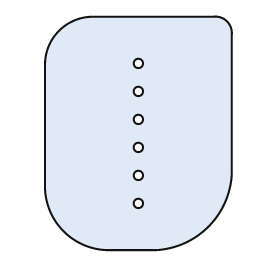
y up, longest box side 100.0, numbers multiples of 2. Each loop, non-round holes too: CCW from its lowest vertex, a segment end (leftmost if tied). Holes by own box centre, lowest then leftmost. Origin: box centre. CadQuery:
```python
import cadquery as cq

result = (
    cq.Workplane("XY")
    .moveTo(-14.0, -50.0)
    .lineTo(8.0, -50.0)
    .threePointArc((30.0, -40.0), (40.0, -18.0))
    .lineTo(40.0, 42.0)
    .threePointArc((38.0, 48.0), (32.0, 50.0))
    .lineTo(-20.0, 50.0)
    .threePointArc((-34.0, 44.0), (-40.0, 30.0))
    .lineTo(-40.0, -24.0)
    .threePointArc((-32.0, -42.0), (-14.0, -50.0))
    .close()
    .moveTo(0.0, -30.0)
    .circle(2.0)
    .moveTo(0.0, -18.0)
    .circle(2.0)
    .moveTo(0.0, -6.0)
    .circle(2.0)
    .moveTo(0.0, 6.0)
    .circle(2.0)
    .moveTo(0.0, 18.0)
    .circle(2.0)
    .moveTo(0.0, 30.0)
    .circle(2.0)
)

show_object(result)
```